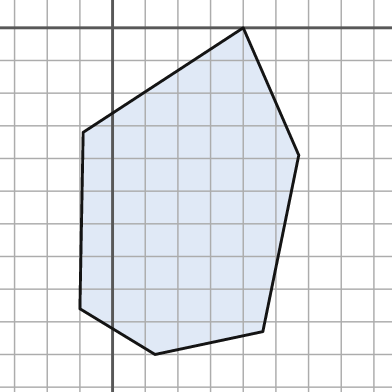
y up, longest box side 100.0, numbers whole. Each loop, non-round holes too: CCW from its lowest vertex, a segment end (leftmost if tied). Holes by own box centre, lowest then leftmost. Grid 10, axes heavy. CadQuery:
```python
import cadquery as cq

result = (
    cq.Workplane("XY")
    .moveTo(13.0, -100.0)
    .lineTo(46.0, -93.0)
    .lineTo(57.0, -39.0)
    .lineTo(40.0, 0.0)
    .lineTo(-9.0, -32.0)
    .lineTo(-10.0, -86.0)
    .close()
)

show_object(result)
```